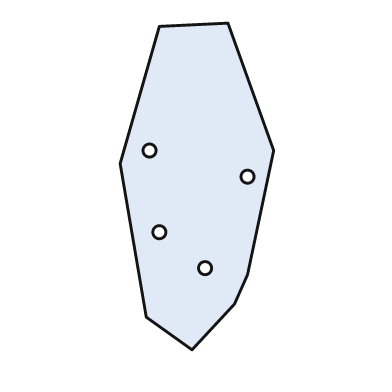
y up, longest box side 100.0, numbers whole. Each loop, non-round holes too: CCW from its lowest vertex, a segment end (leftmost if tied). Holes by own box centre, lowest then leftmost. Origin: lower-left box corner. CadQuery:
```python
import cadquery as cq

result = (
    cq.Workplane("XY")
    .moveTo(22.0, 0.0)
    .lineTo(35.0, 14.0)
    .lineTo(39.0, 23.0)
    .lineTo(47.0, 61.0)
    .lineTo(33.0, 100.0)
    .lineTo(12.0, 99.0)
    .lineTo(0.0, 57.0)
    .lineTo(8.0, 10.0)
    .close()
    .moveTo(26.0, 25.0)
    .circle(2.0)
    .moveTo(12.0, 36.0)
    .circle(2.0)
    .moveTo(39.0, 53.0)
    .circle(2.0)
    .moveTo(9.0, 61.0)
    .circle(2.0)
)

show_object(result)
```